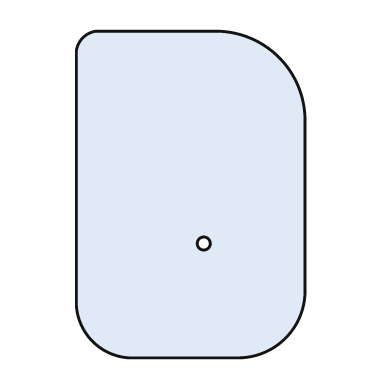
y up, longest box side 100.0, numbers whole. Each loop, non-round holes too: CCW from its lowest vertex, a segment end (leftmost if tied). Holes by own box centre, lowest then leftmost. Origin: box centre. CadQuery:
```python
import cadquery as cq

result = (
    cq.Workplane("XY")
    .moveTo(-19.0, -50.0)
    .lineTo(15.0, -50.0)
    .threePointArc((29.0, -44.0), (35.0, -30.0))
    .lineTo(35.0, 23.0)
    .threePointArc((27.0, 42.0), (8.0, 50.0))
    .lineTo(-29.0, 50.0)
    .threePointArc((-33.0, 48.0), (-35.0, 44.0))
    .lineTo(-35.0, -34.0)
    .threePointArc((-30.0, -45.0), (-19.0, -50.0))
    .close()
    .moveTo(4.0, -15.0)
    .circle(2.0)
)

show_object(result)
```